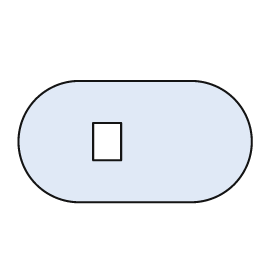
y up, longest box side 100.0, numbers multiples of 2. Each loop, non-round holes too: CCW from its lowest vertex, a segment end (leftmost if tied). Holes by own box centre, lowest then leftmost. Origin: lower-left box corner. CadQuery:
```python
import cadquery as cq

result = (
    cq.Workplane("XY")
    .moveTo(26.0, 0.0)
    .lineTo(74.0, 0.0)
    .threePointArc((100.0, 26.0), (74.0, 52.0))
    .lineTo(26.0, 52.0)
    .threePointArc((0.0, 26.0), (26.0, 0.0))
    .close()
    .moveTo(32.0, 18.0)
    .lineTo(44.0, 18.0)
    .lineTo(44.0, 34.0)
    .lineTo(32.0, 34.0)
    .close()
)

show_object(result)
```